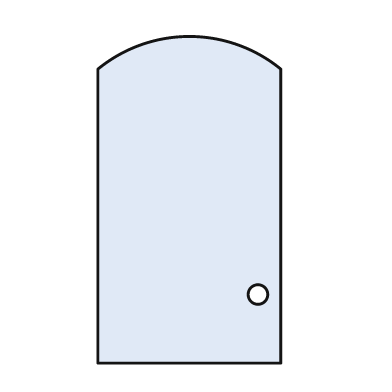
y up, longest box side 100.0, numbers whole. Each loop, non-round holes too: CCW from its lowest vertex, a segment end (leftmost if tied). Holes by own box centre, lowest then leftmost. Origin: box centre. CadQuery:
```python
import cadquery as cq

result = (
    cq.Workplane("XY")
    .moveTo(-28.0, -50.0)
    .lineTo(28.0, -50.0)
    .lineTo(28.0, 40.0)
    .threePointArc((0.0, 50.0), (-28.0, 40.0))
    .close()
    .moveTo(21.0, -29.0)
    .circle(3.0)
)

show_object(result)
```